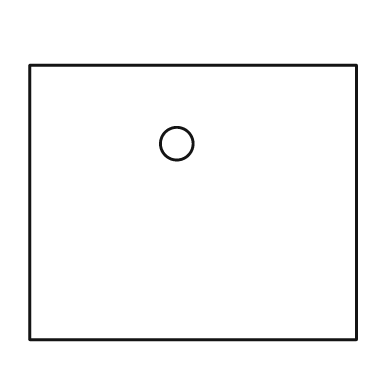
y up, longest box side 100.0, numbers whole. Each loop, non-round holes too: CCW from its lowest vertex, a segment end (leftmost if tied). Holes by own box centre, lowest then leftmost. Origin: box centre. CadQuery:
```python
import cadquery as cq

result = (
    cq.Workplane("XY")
    .moveTo(-50.0, -42.0)
    .lineTo(50.0, -42.0)
    .lineTo(50.0, 42.0)
    .lineTo(-50.0, 42.0)
    .close()
    .moveTo(-5.0, 18.0)
    .circle(5.0)
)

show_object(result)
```